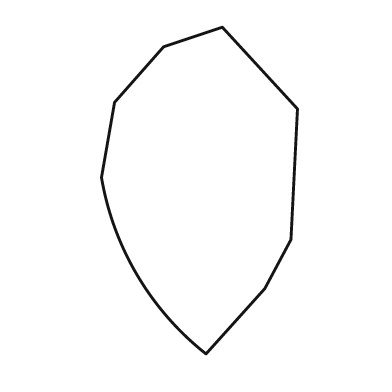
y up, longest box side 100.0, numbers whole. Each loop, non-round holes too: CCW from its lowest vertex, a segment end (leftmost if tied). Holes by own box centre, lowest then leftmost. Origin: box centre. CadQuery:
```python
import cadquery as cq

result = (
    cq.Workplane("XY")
    .moveTo(2.0, -50.0)
    .lineTo(20.0, -30.0)
    .lineTo(28.0, -15.0)
    .lineTo(30.0, 25.0)
    .lineTo(7.0, 50.0)
    .lineTo(-11.0, 44.0)
    .lineTo(-26.0, 27.0)
    .lineTo(-30.0, 4.0)
    .threePointArc((-19.0, -26.0), (2.0, -50.0))
    .close()
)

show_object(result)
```